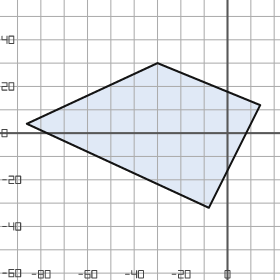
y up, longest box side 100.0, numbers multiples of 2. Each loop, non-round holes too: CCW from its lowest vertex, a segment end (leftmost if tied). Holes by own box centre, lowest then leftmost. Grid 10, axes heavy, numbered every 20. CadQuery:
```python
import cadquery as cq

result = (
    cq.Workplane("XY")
    .moveTo(-8.0, -32.0)
    .lineTo(14.0, 12.0)
    .lineTo(-30.0, 30.0)
    .lineTo(-86.0, 4.0)
    .close()
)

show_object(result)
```